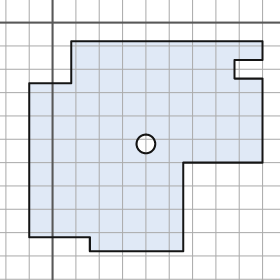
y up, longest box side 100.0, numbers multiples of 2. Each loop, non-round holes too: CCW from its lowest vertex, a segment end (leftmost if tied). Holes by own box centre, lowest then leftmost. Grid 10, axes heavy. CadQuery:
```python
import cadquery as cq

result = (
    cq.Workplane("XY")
    .moveTo(16.0, -98.0)
    .lineTo(56.0, -98.0)
    .lineTo(56.0, -60.0)
    .lineTo(90.0, -60.0)
    .lineTo(90.0, -24.0)
    .lineTo(78.0, -24.0)
    .lineTo(78.0, -16.0)
    .lineTo(90.0, -16.0)
    .lineTo(90.0, -8.0)
    .lineTo(8.0, -8.0)
    .lineTo(8.0, -26.0)
    .lineTo(-10.0, -26.0)
    .lineTo(-10.0, -92.0)
    .lineTo(16.0, -92.0)
    .close()
    .moveTo(40.0, -52.0)
    .circle(4.0)
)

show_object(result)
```